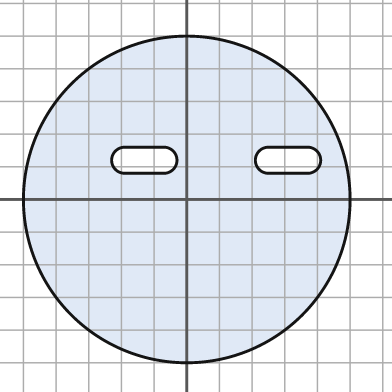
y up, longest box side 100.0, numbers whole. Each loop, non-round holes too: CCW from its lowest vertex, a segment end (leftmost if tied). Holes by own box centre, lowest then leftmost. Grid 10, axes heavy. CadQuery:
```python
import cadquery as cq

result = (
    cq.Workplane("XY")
    .moveTo(0.0, 0.0)
    .circle(50.0)
    .moveTo(-19.0, 8.0)
    .lineTo(-7.0, 8.0)
    .threePointArc((-3.0, 12.0), (-7.0, 16.0))
    .lineTo(-19.0, 16.0)
    .threePointArc((-23.0, 12.0), (-19.0, 8.0))
    .close()
    .moveTo(25.0, 8.0)
    .lineTo(37.0, 8.0)
    .threePointArc((41.0, 12.0), (37.0, 16.0))
    .lineTo(25.0, 16.0)
    .threePointArc((21.0, 12.0), (25.0, 8.0))
    .close()
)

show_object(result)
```